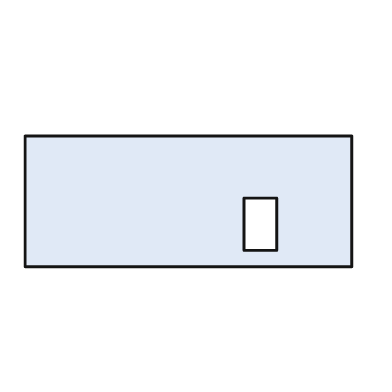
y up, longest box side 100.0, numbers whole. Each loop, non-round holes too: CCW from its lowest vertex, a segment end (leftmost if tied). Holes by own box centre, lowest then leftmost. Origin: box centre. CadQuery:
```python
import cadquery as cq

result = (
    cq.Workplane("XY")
    .moveTo(-50.0, -20.0)
    .lineTo(50.0, -20.0)
    .lineTo(50.0, 20.0)
    .lineTo(-50.0, 20.0)
    .close()
    .moveTo(17.0, -15.0)
    .lineTo(27.0, -15.0)
    .lineTo(27.0, 1.0)
    .lineTo(17.0, 1.0)
    .close()
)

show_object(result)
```